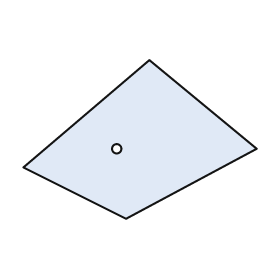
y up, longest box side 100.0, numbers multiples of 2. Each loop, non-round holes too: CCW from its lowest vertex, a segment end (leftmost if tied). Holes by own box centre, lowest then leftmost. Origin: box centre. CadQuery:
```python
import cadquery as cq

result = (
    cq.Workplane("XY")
    .moveTo(-6.0, -34.0)
    .lineTo(50.0, -4.0)
    .lineTo(4.0, 34.0)
    .lineTo(-50.0, -12.0)
    .close()
    .moveTo(-10.0, -4.0)
    .circle(2.0)
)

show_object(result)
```